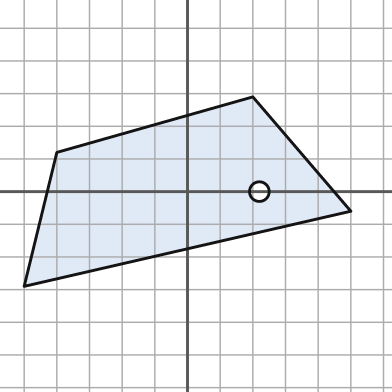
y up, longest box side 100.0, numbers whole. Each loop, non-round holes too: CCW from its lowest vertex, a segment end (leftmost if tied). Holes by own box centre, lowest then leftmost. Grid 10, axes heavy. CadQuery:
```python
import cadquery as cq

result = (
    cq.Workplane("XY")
    .moveTo(-50.0, -29.0)
    .lineTo(50.0, -6.0)
    .lineTo(20.0, 29.0)
    .lineTo(-40.0, 12.0)
    .close()
    .moveTo(22.0, 0.0)
    .circle(3.0)
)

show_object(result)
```